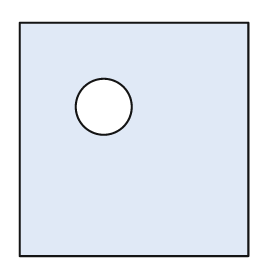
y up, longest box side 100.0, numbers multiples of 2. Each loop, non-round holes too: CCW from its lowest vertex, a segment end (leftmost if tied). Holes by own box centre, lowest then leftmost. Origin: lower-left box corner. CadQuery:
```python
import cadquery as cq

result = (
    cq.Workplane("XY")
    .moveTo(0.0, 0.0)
    .lineTo(98.0, 0.0)
    .lineTo(98.0, 100.0)
    .lineTo(0.0, 100.0)
    .close()
    .moveTo(36.0, 64.0)
    .circle(12.0)
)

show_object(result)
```